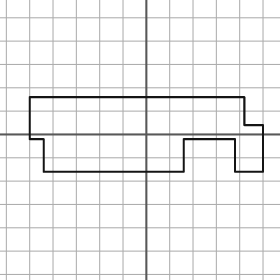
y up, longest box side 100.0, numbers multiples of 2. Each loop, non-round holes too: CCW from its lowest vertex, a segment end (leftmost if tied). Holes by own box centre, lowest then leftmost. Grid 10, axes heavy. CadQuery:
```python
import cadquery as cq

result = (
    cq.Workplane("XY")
    .moveTo(-44.0, -16.0)
    .lineTo(16.0, -16.0)
    .lineTo(16.0, -2.0)
    .lineTo(38.0, -2.0)
    .lineTo(38.0, -16.0)
    .lineTo(50.0, -16.0)
    .lineTo(50.0, 4.0)
    .lineTo(42.0, 4.0)
    .lineTo(42.0, 16.0)
    .lineTo(-50.0, 16.0)
    .lineTo(-50.0, -2.0)
    .lineTo(-44.0, -2.0)
    .close()
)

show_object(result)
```